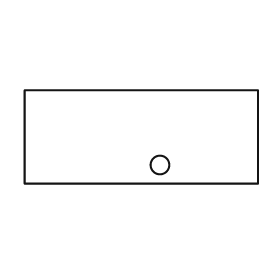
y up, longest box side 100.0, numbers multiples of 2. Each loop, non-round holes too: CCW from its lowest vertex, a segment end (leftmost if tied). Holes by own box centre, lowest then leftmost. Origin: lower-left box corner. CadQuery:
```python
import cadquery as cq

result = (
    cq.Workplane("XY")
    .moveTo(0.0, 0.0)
    .lineTo(100.0, 0.0)
    .lineTo(100.0, 40.0)
    .lineTo(0.0, 40.0)
    .close()
    .moveTo(58.0, 8.0)
    .circle(4.0)
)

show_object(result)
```